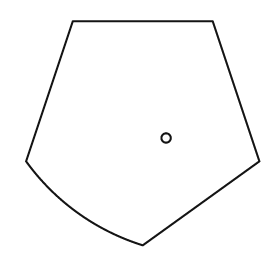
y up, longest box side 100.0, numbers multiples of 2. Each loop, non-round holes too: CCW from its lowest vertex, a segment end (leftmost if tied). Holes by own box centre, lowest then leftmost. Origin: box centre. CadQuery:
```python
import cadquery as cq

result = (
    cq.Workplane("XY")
    .moveTo(0.0, -48.0)
    .lineTo(50.0, -12.0)
    .lineTo(30.0, 48.0)
    .lineTo(-30.0, 48.0)
    .lineTo(-50.0, -12.0)
    .threePointArc((-28.0, -34.0), (0.0, -48.0))
    .close()
    .moveTo(10.0, -2.0)
    .circle(2.0)
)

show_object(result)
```